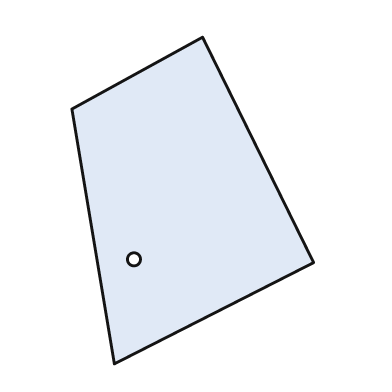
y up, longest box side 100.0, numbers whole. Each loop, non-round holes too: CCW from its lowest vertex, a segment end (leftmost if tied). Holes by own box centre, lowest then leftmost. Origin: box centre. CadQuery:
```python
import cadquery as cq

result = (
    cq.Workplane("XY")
    .moveTo(-24.0, -50.0)
    .lineTo(37.0, -19.0)
    .lineTo(3.0, 50.0)
    .lineTo(-37.0, 28.0)
    .close()
    .moveTo(-18.0, -18.0)
    .circle(2.0)
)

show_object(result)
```